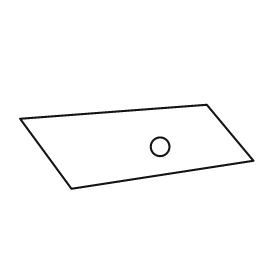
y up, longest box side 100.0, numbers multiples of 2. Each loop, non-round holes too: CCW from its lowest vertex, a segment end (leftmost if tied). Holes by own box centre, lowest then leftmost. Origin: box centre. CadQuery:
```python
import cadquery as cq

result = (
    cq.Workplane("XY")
    .moveTo(-28.0, -18.0)
    .lineTo(50.0, -6.0)
    .lineTo(30.0, 18.0)
    .lineTo(-50.0, 12.0)
    .close()
    .moveTo(10.0, 0.0)
    .circle(4.0)
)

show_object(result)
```